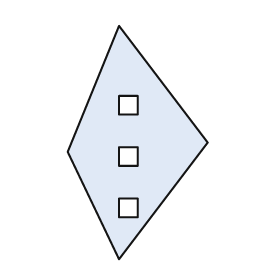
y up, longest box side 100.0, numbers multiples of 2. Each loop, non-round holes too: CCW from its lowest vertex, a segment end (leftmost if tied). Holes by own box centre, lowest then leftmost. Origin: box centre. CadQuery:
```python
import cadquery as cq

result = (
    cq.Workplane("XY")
    .moveTo(-8.0, -50.0)
    .lineTo(30.0, 0.0)
    .lineTo(-8.0, 50.0)
    .lineTo(-30.0, -4.0)
    .close()
    .moveTo(-8.0, -32.0)
    .lineTo(0.0, -32.0)
    .lineTo(0.0, -24.0)
    .lineTo(-8.0, -24.0)
    .close()
    .moveTo(-8.0, -10.0)
    .lineTo(0.0, -10.0)
    .lineTo(0.0, -2.0)
    .lineTo(-8.0, -2.0)
    .close()
    .moveTo(-8.0, 12.0)
    .lineTo(0.0, 12.0)
    .lineTo(0.0, 20.0)
    .lineTo(-8.0, 20.0)
    .close()
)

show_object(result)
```